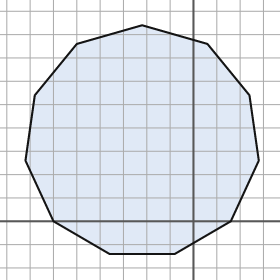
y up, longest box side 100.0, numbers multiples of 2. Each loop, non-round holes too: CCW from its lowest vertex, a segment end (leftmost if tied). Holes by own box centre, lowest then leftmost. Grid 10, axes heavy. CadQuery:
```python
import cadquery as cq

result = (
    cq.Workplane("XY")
    .moveTo(-36.0, -14.0)
    .lineTo(-8.0, -14.0)
    .lineTo(16.0, 0.0)
    .lineTo(28.0, 26.0)
    .lineTo(24.0, 54.0)
    .lineTo(6.0, 76.0)
    .lineTo(-22.0, 84.0)
    .lineTo(-50.0, 76.0)
    .lineTo(-68.0, 54.0)
    .lineTo(-72.0, 26.0)
    .lineTo(-60.0, 0.0)
    .close()
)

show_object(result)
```